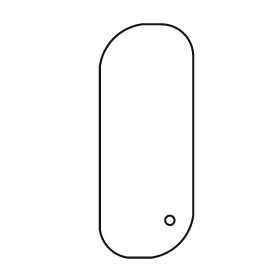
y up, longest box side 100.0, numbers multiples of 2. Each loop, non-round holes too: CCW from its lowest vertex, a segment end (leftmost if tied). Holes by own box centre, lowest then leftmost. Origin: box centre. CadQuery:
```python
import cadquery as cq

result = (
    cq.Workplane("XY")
    .moveTo(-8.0, -50.0)
    .lineTo(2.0, -50.0)
    .threePointArc((14.0, -44.0), (20.0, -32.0))
    .lineTo(20.0, 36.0)
    .threePointArc((16.0, 46.0), (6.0, 50.0))
    .lineTo(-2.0, 50.0)
    .threePointArc((-14.0, 44.0), (-20.0, 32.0))
    .lineTo(-20.0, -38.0)
    .threePointArc((-16.0, -46.0), (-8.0, -50.0))
    .close()
    .moveTo(10.0, -34.0)
    .circle(2.0)
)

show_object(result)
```